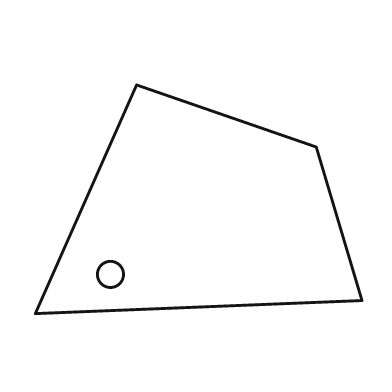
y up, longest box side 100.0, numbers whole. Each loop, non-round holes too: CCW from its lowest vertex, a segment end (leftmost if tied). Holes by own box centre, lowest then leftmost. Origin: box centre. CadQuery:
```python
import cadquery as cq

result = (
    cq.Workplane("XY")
    .moveTo(-50.0, -35.0)
    .lineTo(50.0, -31.0)
    .lineTo(36.0, 16.0)
    .lineTo(-19.0, 35.0)
    .close()
    .moveTo(-27.0, -23.0)
    .circle(4.0)
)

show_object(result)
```